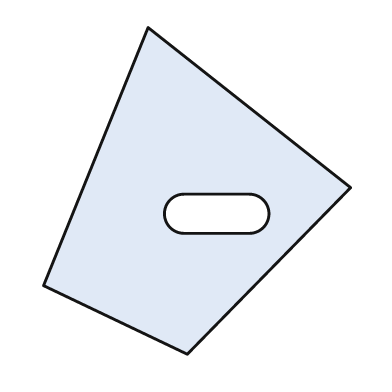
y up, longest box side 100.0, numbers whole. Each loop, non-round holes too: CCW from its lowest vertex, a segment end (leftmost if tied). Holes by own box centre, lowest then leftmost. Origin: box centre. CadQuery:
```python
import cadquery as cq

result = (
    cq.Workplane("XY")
    .moveTo(-3.0, -50.0)
    .lineTo(47.0, 1.0)
    .lineTo(-15.0, 50.0)
    .lineTo(-47.0, -29.0)
    .close()
    .moveTo(-4.0, -13.0)
    .lineTo(16.0, -13.0)
    .threePointArc((22.0, -7.0), (16.0, -1.0))
    .lineTo(-4.0, -1.0)
    .threePointArc((-10.0, -7.0), (-4.0, -13.0))
    .close()
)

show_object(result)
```